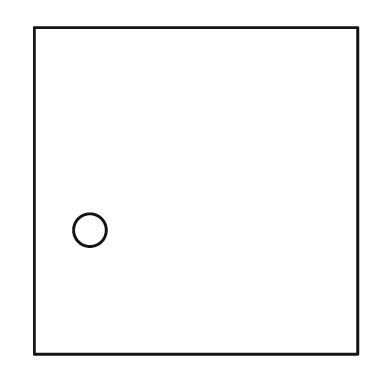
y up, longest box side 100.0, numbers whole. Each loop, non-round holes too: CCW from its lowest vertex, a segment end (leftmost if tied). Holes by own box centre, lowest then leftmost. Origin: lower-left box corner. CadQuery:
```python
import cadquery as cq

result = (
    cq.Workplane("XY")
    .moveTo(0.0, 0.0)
    .lineTo(99.0, 0.0)
    .lineTo(99.0, 100.0)
    .lineTo(0.0, 100.0)
    .close()
    .moveTo(17.0, 38.0)
    .circle(5.0)
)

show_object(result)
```